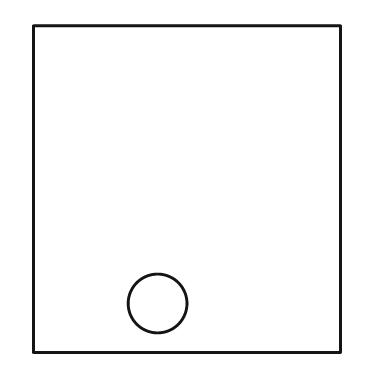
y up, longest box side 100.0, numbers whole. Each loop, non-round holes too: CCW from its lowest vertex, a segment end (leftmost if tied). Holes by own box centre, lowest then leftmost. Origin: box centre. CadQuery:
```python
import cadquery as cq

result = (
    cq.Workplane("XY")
    .moveTo(-47.0, -50.0)
    .lineTo(47.0, -50.0)
    .lineTo(47.0, 50.0)
    .lineTo(-47.0, 50.0)
    .close()
    .moveTo(-9.0, -35.0)
    .circle(9.0)
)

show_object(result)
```